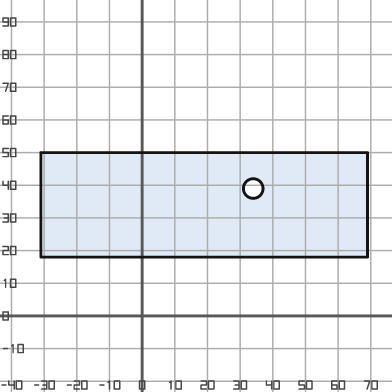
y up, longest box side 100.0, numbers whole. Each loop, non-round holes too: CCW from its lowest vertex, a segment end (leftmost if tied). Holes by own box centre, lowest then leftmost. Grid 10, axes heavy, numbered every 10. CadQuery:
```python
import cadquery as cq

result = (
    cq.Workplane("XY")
    .moveTo(-31.0, 18.0)
    .lineTo(69.0, 18.0)
    .lineTo(69.0, 50.0)
    .lineTo(-31.0, 50.0)
    .close()
    .moveTo(34.0, 39.0)
    .circle(3.0)
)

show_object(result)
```